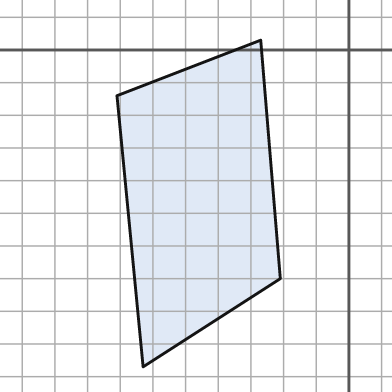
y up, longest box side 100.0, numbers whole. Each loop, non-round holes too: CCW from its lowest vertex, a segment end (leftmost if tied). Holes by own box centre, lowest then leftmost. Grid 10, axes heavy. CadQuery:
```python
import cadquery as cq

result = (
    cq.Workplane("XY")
    .moveTo(-63.0, -97.0)
    .lineTo(-21.0, -70.0)
    .lineTo(-27.0, 3.0)
    .lineTo(-71.0, -14.0)
    .close()
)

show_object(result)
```